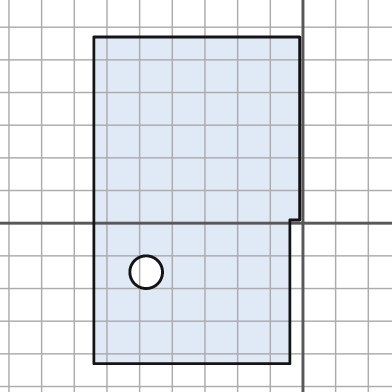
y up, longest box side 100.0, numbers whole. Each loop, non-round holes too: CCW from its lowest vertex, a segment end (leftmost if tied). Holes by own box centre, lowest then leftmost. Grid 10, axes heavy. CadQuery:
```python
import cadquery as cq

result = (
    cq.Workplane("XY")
    .moveTo(-64.0, -43.0)
    .lineTo(-4.0, -43.0)
    .lineTo(-4.0, 1.0)
    .lineTo(-1.0, 1.0)
    .lineTo(-1.0, 57.0)
    .lineTo(-64.0, 57.0)
    .close()
    .moveTo(-48.0, -15.0)
    .circle(5.0)
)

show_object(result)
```